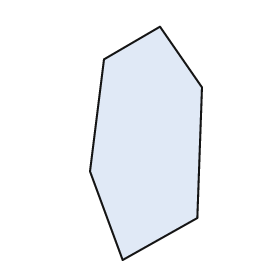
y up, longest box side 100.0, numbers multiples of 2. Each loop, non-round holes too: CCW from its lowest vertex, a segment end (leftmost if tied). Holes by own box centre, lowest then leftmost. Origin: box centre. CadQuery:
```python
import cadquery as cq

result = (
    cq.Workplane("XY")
    .moveTo(-10.0, -50.0)
    .lineTo(22.0, -32.0)
    .lineTo(24.0, 24.0)
    .lineTo(6.0, 50.0)
    .lineTo(-18.0, 36.0)
    .lineTo(-24.0, -12.0)
    .close()
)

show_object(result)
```